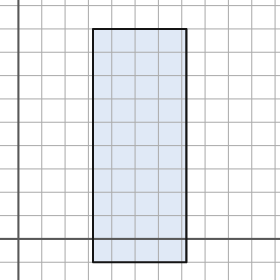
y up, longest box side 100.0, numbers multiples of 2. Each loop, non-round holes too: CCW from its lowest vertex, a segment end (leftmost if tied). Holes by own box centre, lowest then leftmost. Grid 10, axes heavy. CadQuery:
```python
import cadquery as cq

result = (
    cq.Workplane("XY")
    .moveTo(32.0, -10.0)
    .lineTo(72.0, -10.0)
    .lineTo(72.0, 90.0)
    .lineTo(32.0, 90.0)
    .close()
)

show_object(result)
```